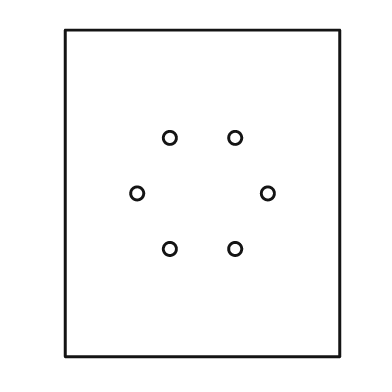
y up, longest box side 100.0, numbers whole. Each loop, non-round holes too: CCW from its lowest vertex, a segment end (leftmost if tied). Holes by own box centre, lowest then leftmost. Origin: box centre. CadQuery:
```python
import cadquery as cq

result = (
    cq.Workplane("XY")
    .moveTo(-42.0, -50.0)
    .lineTo(42.0, -50.0)
    .lineTo(42.0, 50.0)
    .lineTo(-42.0, 50.0)
    .close()
    .moveTo(-10.0, -17.0)
    .circle(2.0)
    .moveTo(10.0, -17.0)
    .circle(2.0)
    .moveTo(-20.0, 0.0)
    .circle(2.0)
    .moveTo(20.0, 0.0)
    .circle(2.0)
    .moveTo(-10.0, 17.0)
    .circle(2.0)
    .moveTo(10.0, 17.0)
    .circle(2.0)
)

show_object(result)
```